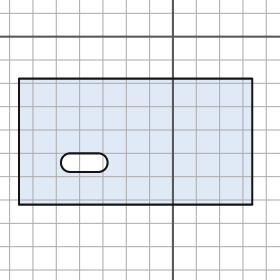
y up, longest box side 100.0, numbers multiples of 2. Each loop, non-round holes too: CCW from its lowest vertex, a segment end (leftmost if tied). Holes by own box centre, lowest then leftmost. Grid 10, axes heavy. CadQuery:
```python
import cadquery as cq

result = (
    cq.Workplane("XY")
    .moveTo(-66.0, -72.0)
    .lineTo(34.0, -72.0)
    .lineTo(34.0, -18.0)
    .lineTo(-66.0, -18.0)
    .close()
    .moveTo(-44.0, -58.0)
    .lineTo(-32.0, -58.0)
    .threePointArc((-28.0, -54.0), (-32.0, -50.0))
    .lineTo(-44.0, -50.0)
    .threePointArc((-48.0, -54.0), (-44.0, -58.0))
    .close()
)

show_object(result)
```